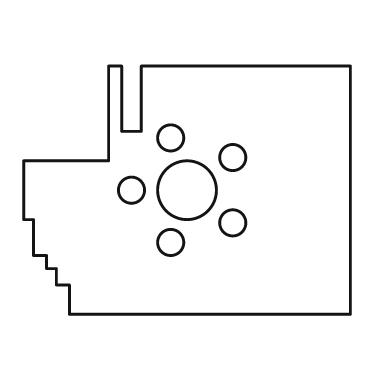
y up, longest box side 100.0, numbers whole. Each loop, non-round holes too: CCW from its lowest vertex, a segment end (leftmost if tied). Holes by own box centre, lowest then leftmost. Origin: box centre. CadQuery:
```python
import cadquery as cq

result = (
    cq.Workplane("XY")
    .moveTo(-36.0, -38.0)
    .lineTo(50.0, -38.0)
    .lineTo(50.0, 38.0)
    .lineTo(-14.0, 38.0)
    .lineTo(-14.0, 18.0)
    .lineTo(-20.0, 18.0)
    .lineTo(-20.0, 38.0)
    .lineTo(-24.0, 38.0)
    .lineTo(-24.0, 9.0)
    .lineTo(-50.0, 9.0)
    .lineTo(-50.0, -9.0)
    .lineTo(-47.0, -9.0)
    .lineTo(-47.0, -20.0)
    .lineTo(-43.0, -20.0)
    .lineTo(-43.0, -24.0)
    .lineTo(-40.0, -24.0)
    .lineTo(-40.0, -29.0)
    .lineTo(-36.0, -29.0)
    .close()
    .moveTo(-5.0, -16.0)
    .circle(4.0)
    .moveTo(14.0, -10.0)
    .circle(4.0)
    .moveTo(-17.0, 0.0)
    .circle(4.0)
    .moveTo(0.0, 0.0)
    .circle(9.0)
    .moveTo(14.0, 10.0)
    .circle(4.0)
    .moveTo(-5.0, 16.0)
    .circle(4.0)
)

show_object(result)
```